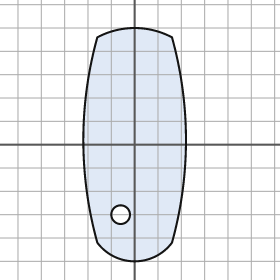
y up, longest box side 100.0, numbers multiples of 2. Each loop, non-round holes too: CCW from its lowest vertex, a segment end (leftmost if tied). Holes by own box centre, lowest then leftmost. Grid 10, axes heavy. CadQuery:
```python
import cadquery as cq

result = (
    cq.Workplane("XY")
    .moveTo(-16.0, -42.0)
    .threePointArc((0.0, -50.0), (16.0, -42.0))
    .threePointArc((22.0, 2.0), (16.0, 46.0))
    .threePointArc((0.0, 50.0), (-16.0, 46.0))
    .threePointArc((-22.0, 2.0), (-16.0, -42.0))
    .close()
    .moveTo(-6.0, -30.0)
    .circle(4.0)
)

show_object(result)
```